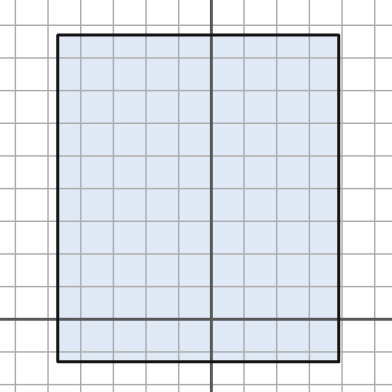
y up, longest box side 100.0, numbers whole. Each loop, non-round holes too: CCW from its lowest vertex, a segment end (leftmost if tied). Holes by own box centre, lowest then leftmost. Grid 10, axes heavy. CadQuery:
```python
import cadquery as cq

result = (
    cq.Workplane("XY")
    .moveTo(-47.0, -13.0)
    .lineTo(39.0, -13.0)
    .lineTo(39.0, 87.0)
    .lineTo(-47.0, 87.0)
    .close()
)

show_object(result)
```